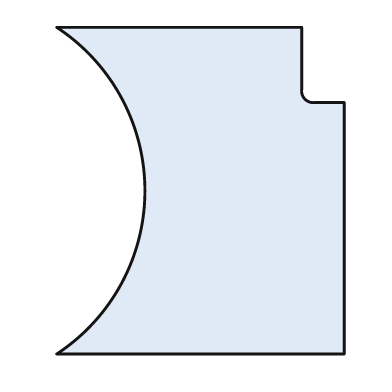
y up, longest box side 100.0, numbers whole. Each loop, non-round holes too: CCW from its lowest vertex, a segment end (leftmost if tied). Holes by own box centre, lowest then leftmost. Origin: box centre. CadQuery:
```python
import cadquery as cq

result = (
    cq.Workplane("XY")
    .moveTo(-44.0, -50.0)
    .lineTo(44.0, -50.0)
    .lineTo(44.0, 27.0)
    .lineTo(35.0, 27.0)
    .threePointArc((32.0, 28.0), (31.0, 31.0))
    .lineTo(31.0, 50.0)
    .lineTo(-44.0, 50.0)
    .threePointArc((-17.0, 0.0), (-44.0, -50.0))
    .close()
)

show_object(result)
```